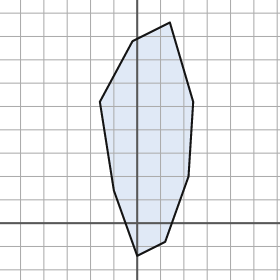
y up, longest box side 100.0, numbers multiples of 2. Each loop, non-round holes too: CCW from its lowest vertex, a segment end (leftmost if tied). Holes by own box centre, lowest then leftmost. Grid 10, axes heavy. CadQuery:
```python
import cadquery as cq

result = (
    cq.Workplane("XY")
    .moveTo(0.0, -14.0)
    .lineTo(12.0, -8.0)
    .lineTo(22.0, 20.0)
    .lineTo(24.0, 52.0)
    .lineTo(14.0, 86.0)
    .lineTo(-2.0, 78.0)
    .lineTo(-16.0, 52.0)
    .lineTo(-10.0, 14.0)
    .close()
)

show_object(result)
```